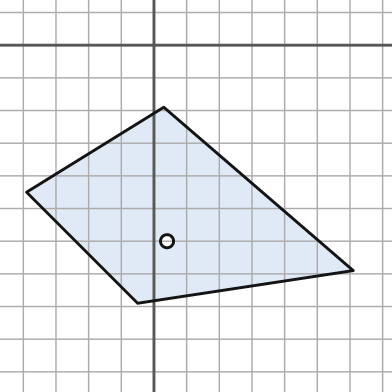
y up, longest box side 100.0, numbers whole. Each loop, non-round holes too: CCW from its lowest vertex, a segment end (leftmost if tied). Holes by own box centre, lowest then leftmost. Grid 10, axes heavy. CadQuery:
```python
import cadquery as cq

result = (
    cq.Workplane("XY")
    .moveTo(-5.0, -79.0)
    .lineTo(61.0, -69.0)
    .lineTo(3.0, -19.0)
    .lineTo(-39.0, -45.0)
    .close()
    .moveTo(4.0, -60.0)
    .circle(2.0)
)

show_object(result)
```